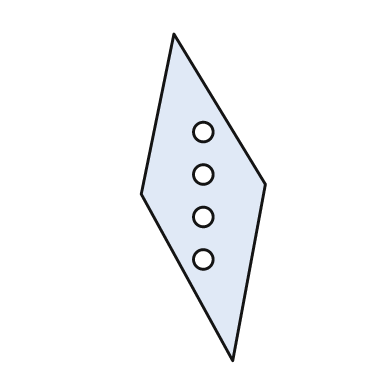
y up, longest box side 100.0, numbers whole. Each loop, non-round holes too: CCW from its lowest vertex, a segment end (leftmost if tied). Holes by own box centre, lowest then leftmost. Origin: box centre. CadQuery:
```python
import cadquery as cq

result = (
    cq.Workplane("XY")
    .moveTo(9.0, -50.0)
    .lineTo(19.0, 4.0)
    .lineTo(-9.0, 50.0)
    .lineTo(-19.0, 1.0)
    .close()
    .moveTo(0.0, -19.0)
    .circle(3.0)
    .moveTo(0.0, -6.0)
    .circle(3.0)
    .moveTo(0.0, 7.0)
    .circle(3.0)
    .moveTo(0.0, 20.0)
    .circle(3.0)
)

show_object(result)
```